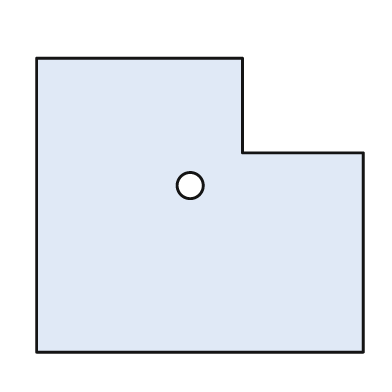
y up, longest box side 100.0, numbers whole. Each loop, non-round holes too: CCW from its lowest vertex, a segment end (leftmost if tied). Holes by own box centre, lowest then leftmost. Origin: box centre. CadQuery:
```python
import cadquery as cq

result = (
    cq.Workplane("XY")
    .moveTo(-50.0, -45.0)
    .lineTo(50.0, -45.0)
    .lineTo(50.0, 16.0)
    .lineTo(13.0, 16.0)
    .lineTo(13.0, 45.0)
    .lineTo(-50.0, 45.0)
    .close()
    .moveTo(-3.0, 6.0)
    .circle(4.0)
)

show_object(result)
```